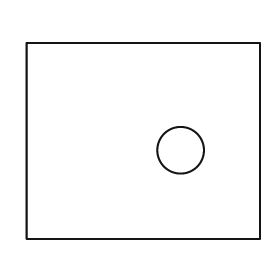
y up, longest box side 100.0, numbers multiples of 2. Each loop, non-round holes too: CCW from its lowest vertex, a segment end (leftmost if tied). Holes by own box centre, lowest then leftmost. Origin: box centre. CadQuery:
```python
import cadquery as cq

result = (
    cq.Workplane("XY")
    .moveTo(-50.0, -42.0)
    .lineTo(50.0, -42.0)
    .lineTo(50.0, 42.0)
    .lineTo(-50.0, 42.0)
    .close()
    .moveTo(16.0, -4.0)
    .circle(10.0)
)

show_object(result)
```